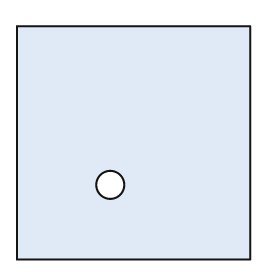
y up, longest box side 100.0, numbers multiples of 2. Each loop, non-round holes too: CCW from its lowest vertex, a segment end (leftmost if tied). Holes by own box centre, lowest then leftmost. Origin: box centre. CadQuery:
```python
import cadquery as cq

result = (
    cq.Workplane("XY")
    .moveTo(-50.0, -50.0)
    .lineTo(50.0, -50.0)
    .lineTo(50.0, 50.0)
    .lineTo(-50.0, 50.0)
    .close()
    .moveTo(-10.0, -18.0)
    .circle(6.0)
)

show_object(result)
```